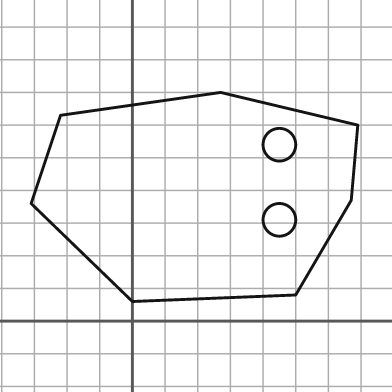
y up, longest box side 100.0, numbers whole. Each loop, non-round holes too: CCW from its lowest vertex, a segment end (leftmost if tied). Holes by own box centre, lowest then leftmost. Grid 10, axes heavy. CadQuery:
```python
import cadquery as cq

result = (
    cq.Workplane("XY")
    .moveTo(0.0, 6.0)
    .lineTo(50.0, 8.0)
    .lineTo(67.0, 37.0)
    .lineTo(69.0, 60.0)
    .lineTo(27.0, 70.0)
    .lineTo(-22.0, 63.0)
    .lineTo(-31.0, 36.0)
    .close()
    .moveTo(45.0, 31.0)
    .circle(5.0)
    .moveTo(45.0, 54.0)
    .circle(5.0)
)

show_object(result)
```